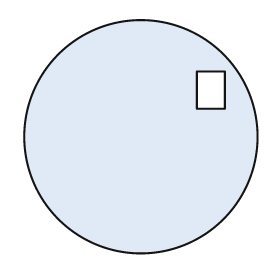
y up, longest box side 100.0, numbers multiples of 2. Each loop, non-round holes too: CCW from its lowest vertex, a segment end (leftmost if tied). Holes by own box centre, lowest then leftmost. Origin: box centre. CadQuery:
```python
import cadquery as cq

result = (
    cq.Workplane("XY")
    .moveTo(0.0, 0.0)
    .circle(50.0)
    .moveTo(24.0, 12.0)
    .lineTo(36.0, 12.0)
    .lineTo(36.0, 28.0)
    .lineTo(24.0, 28.0)
    .close()
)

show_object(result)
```